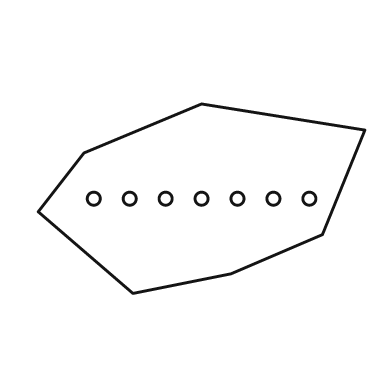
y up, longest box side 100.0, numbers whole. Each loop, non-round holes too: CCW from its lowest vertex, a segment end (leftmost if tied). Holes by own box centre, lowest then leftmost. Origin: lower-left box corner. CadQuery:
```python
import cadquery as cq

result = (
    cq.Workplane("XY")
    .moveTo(29.0, 0.0)
    .lineTo(59.0, 6.0)
    .lineTo(87.0, 18.0)
    .lineTo(100.0, 50.0)
    .lineTo(50.0, 58.0)
    .lineTo(14.0, 43.0)
    .lineTo(0.0, 25.0)
    .close()
    .moveTo(17.0, 29.0)
    .circle(2.0)
    .moveTo(28.0, 29.0)
    .circle(2.0)
    .moveTo(39.0, 29.0)
    .circle(2.0)
    .moveTo(50.0, 29.0)
    .circle(2.0)
    .moveTo(61.0, 29.0)
    .circle(2.0)
    .moveTo(72.0, 29.0)
    .circle(2.0)
    .moveTo(83.0, 29.0)
    .circle(2.0)
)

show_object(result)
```